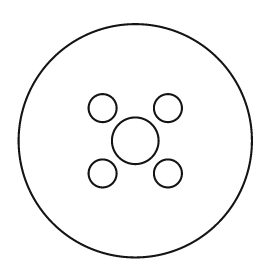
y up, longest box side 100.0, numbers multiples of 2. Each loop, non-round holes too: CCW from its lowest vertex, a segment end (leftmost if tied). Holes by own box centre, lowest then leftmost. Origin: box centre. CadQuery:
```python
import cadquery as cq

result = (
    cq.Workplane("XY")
    .moveTo(0.0, 0.0)
    .circle(50.0)
    .moveTo(-14.0, -14.0)
    .circle(6.0)
    .moveTo(14.0, -14.0)
    .circle(6.0)
    .moveTo(0.0, 0.0)
    .circle(10.0)
    .moveTo(-14.0, 14.0)
    .circle(6.0)
    .moveTo(14.0, 14.0)
    .circle(6.0)
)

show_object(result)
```